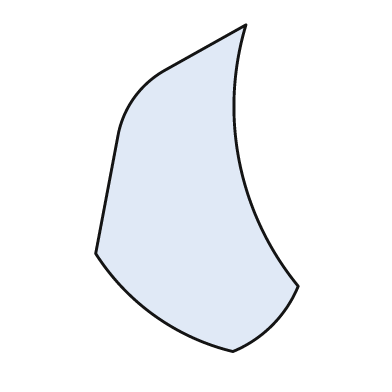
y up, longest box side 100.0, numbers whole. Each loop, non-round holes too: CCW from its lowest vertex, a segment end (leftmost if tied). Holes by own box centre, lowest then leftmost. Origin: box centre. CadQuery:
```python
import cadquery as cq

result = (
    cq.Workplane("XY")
    .moveTo(11.0, -50.0)
    .threePointArc((23.0, -42.0), (31.0, -30.0))
    .threePointArc((13.0, 8.0), (15.0, 50.0))
    .lineTo(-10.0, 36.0)
    .threePointArc((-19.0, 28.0), (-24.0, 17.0))
    .lineTo(-31.0, -20.0)
    .threePointArc((-13.0, -39.0), (11.0, -50.0))
    .close()
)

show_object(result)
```